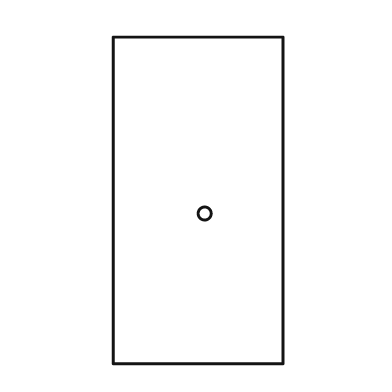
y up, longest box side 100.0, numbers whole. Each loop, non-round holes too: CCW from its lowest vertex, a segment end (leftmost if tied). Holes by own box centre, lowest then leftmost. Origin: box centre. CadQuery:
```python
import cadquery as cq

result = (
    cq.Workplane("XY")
    .moveTo(-26.0, -50.0)
    .lineTo(26.0, -50.0)
    .lineTo(26.0, 50.0)
    .lineTo(-26.0, 50.0)
    .close()
    .moveTo(2.0, -4.0)
    .circle(2.0)
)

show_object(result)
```